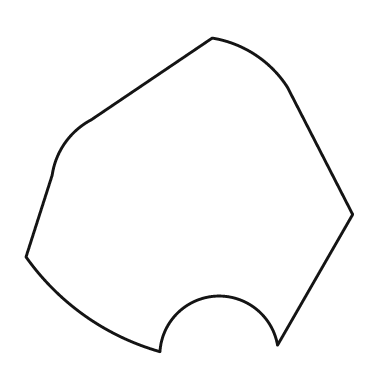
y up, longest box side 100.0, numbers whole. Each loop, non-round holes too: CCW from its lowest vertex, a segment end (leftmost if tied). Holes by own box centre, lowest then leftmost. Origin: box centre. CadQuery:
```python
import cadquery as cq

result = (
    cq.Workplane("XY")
    .moveTo(-9.0, -48.0)
    .threePointArc((8.0, -31.0), (27.0, -46.0))
    .lineTo(50.0, -6.0)
    .lineTo(30.0, 33.0)
    .threePointArc((20.0, 43.0), (7.0, 48.0))
    .lineTo(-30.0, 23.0)
    .threePointArc((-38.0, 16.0), (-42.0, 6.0))
    .lineTo(-50.0, -19.0)
    .threePointArc((-32.0, -37.0), (-9.0, -48.0))
    .close()
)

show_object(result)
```